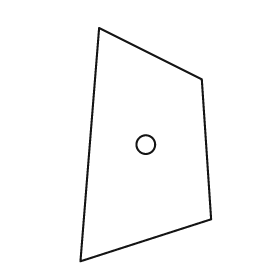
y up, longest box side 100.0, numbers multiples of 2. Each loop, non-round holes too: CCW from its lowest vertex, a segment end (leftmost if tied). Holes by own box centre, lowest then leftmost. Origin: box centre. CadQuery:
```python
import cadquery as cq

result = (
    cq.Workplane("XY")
    .moveTo(-28.0, -50.0)
    .lineTo(28.0, -32.0)
    .lineTo(24.0, 28.0)
    .lineTo(-20.0, 50.0)
    .close()
    .moveTo(0.0, 0.0)
    .circle(4.0)
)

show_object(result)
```